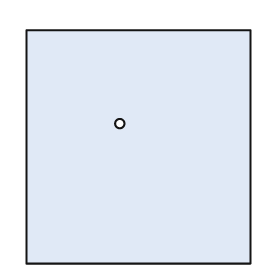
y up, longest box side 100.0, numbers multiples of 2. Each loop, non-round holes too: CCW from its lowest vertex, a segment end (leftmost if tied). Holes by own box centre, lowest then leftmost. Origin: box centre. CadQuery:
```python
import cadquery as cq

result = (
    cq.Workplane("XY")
    .moveTo(-48.0, -50.0)
    .lineTo(48.0, -50.0)
    .lineTo(48.0, 50.0)
    .lineTo(-48.0, 50.0)
    .close()
    .moveTo(-8.0, 10.0)
    .circle(2.0)
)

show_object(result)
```